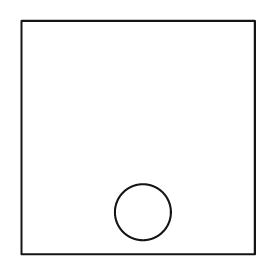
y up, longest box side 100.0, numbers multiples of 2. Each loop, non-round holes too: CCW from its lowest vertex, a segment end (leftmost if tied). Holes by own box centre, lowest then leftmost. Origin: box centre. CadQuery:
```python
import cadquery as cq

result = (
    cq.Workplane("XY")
    .moveTo(-50.0, -50.0)
    .lineTo(50.0, -50.0)
    .lineTo(50.0, 50.0)
    .lineTo(-50.0, 50.0)
    .close()
    .moveTo(2.0, -32.0)
    .circle(12.0)
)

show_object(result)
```